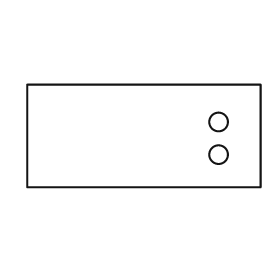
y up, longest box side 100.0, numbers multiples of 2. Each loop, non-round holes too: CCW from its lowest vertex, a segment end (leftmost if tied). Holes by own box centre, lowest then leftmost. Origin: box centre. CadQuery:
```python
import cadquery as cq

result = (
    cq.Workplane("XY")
    .moveTo(-50.0, -22.0)
    .lineTo(50.0, -22.0)
    .lineTo(50.0, 22.0)
    .lineTo(-50.0, 22.0)
    .close()
    .moveTo(32.0, -8.0)
    .circle(4.0)
    .moveTo(32.0, 6.0)
    .circle(4.0)
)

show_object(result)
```